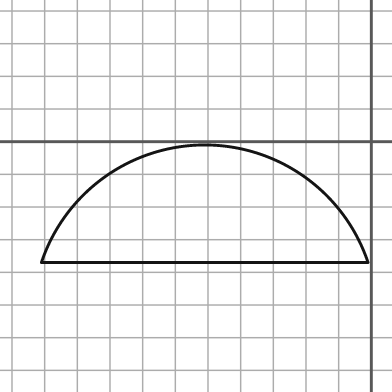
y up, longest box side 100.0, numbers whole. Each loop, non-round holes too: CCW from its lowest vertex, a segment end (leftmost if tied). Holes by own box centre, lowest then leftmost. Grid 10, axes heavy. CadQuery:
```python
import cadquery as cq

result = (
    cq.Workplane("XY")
    .moveTo(-101.0, -37.0)
    .lineTo(-1.0, -37.0)
    .threePointArc((-51.0, -1.0), (-101.0, -37.0))
    .close()
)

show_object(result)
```